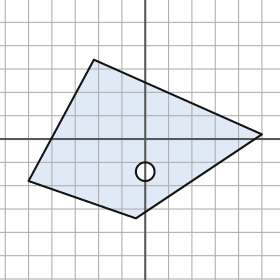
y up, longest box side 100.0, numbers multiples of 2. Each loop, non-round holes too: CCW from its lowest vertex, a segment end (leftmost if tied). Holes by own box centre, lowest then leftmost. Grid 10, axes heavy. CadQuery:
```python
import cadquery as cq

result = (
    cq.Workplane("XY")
    .moveTo(-4.0, -34.0)
    .lineTo(50.0, 2.0)
    .lineTo(-22.0, 34.0)
    .lineTo(-50.0, -18.0)
    .close()
    .moveTo(0.0, -14.0)
    .circle(4.0)
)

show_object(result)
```